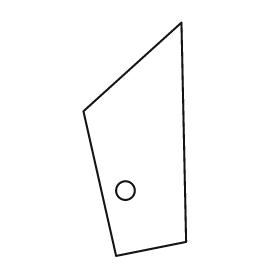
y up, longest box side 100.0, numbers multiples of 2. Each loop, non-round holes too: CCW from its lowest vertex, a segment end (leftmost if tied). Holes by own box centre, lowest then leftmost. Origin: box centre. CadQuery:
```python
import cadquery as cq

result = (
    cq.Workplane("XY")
    .moveTo(-8.0, -50.0)
    .lineTo(22.0, -44.0)
    .lineTo(20.0, 50.0)
    .lineTo(-22.0, 12.0)
    .close()
    .moveTo(-4.0, -22.0)
    .circle(4.0)
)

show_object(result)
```